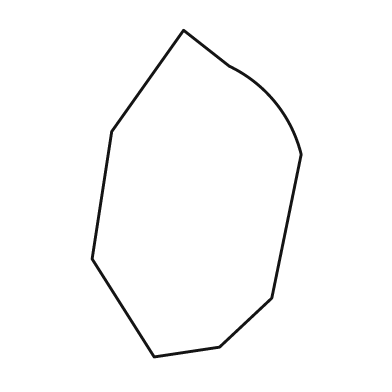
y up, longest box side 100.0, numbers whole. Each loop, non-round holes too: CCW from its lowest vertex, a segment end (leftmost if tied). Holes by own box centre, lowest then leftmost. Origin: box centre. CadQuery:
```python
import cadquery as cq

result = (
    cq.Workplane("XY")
    .moveTo(-13.0, -50.0)
    .lineTo(7.0, -47.0)
    .lineTo(23.0, -32.0)
    .lineTo(32.0, 12.0)
    .threePointArc((24.0, 28.0), (10.0, 39.0))
    .lineTo(-4.0, 50.0)
    .lineTo(-26.0, 19.0)
    .lineTo(-32.0, -20.0)
    .close()
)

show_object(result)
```